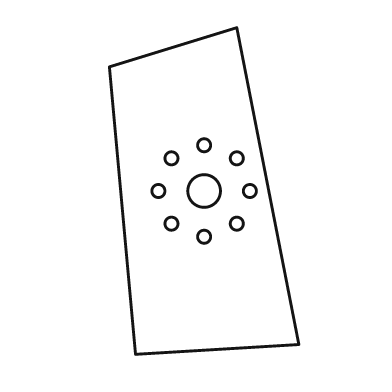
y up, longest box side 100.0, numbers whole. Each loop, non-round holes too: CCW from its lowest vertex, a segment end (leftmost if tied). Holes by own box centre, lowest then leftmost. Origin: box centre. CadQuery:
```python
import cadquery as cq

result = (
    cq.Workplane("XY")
    .moveTo(-21.0, -50.0)
    .lineTo(29.0, -47.0)
    .lineTo(10.0, 50.0)
    .lineTo(-29.0, 38.0)
    .close()
    .moveTo(0.0, -14.0)
    .circle(2.0)
    .moveTo(-10.0, -10.0)
    .circle(2.0)
    .moveTo(10.0, -10.0)
    .circle(2.0)
    .moveTo(-14.0, 0.0)
    .circle(2.0)
    .moveTo(0.0, 0.0)
    .circle(5.0)
    .moveTo(14.0, 0.0)
    .circle(2.0)
    .moveTo(-10.0, 10.0)
    .circle(2.0)
    .moveTo(10.0, 10.0)
    .circle(2.0)
    .moveTo(0.0, 14.0)
    .circle(2.0)
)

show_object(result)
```